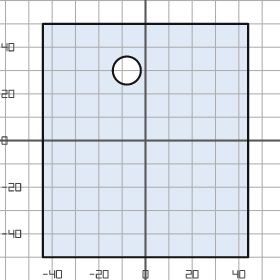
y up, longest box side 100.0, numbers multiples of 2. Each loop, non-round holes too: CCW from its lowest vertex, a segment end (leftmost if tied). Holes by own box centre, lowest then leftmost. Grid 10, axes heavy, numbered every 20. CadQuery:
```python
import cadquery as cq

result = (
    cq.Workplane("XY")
    .moveTo(-44.0, -50.0)
    .lineTo(44.0, -50.0)
    .lineTo(44.0, 50.0)
    .lineTo(-44.0, 50.0)
    .close()
    .moveTo(-8.0, 30.0)
    .circle(6.0)
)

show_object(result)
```